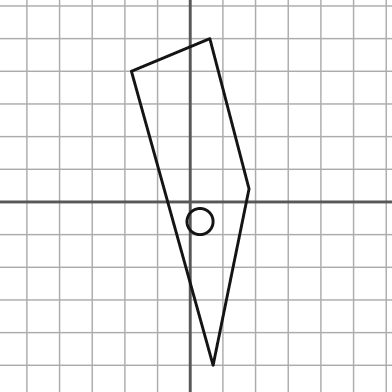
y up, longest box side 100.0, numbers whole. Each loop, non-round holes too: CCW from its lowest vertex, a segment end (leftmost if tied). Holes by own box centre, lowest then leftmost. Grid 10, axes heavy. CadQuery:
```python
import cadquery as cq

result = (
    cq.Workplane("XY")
    .moveTo(7.0, -50.0)
    .lineTo(18.0, 4.0)
    .lineTo(6.0, 50.0)
    .lineTo(-18.0, 40.0)
    .close()
    .moveTo(3.0, -6.0)
    .circle(4.0)
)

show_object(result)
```